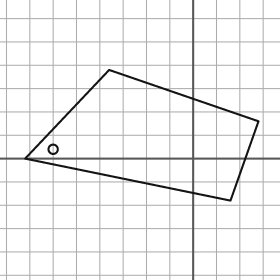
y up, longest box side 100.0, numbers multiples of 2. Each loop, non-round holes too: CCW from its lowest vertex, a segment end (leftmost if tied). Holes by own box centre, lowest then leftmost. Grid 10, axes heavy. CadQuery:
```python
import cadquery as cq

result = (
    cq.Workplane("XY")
    .moveTo(16.0, -18.0)
    .lineTo(28.0, 16.0)
    .lineTo(-36.0, 38.0)
    .lineTo(-72.0, 0.0)
    .close()
    .moveTo(-60.0, 4.0)
    .circle(2.0)
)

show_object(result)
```